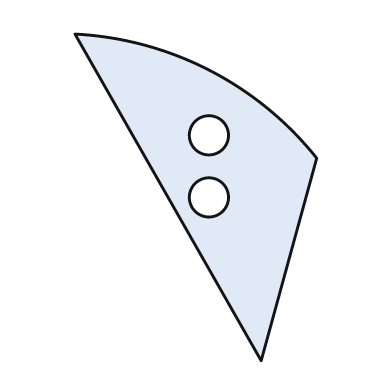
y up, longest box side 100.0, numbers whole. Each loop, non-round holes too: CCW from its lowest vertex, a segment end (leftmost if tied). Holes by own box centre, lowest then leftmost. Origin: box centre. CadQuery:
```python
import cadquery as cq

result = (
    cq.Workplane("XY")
    .moveTo(20.0, -50.0)
    .lineTo(37.0, 12.0)
    .threePointArc((4.0, 39.0), (-37.0, 50.0))
    .close()
    .moveTo(4.0, 0.0)
    .circle(6.0)
    .moveTo(4.0, 19.0)
    .circle(6.0)
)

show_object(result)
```